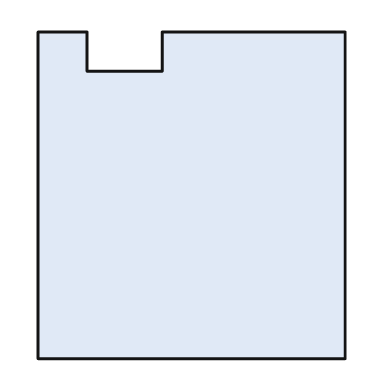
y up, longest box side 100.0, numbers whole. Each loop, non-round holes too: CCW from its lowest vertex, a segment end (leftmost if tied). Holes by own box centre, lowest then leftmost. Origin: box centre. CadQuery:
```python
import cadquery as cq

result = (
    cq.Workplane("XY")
    .moveTo(-47.0, -50.0)
    .lineTo(47.0, -50.0)
    .lineTo(47.0, 50.0)
    .lineTo(-9.0, 50.0)
    .lineTo(-9.0, 38.0)
    .lineTo(-32.0, 38.0)
    .lineTo(-32.0, 50.0)
    .lineTo(-47.0, 50.0)
    .close()
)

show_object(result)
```